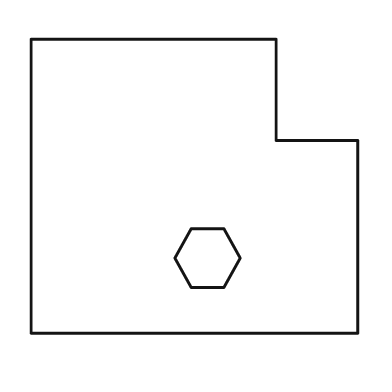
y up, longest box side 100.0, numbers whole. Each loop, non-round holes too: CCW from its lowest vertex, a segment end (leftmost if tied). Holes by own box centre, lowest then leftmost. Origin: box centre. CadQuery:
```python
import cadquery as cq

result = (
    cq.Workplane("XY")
    .moveTo(-50.0, -45.0)
    .lineTo(50.0, -45.0)
    .lineTo(50.0, 14.0)
    .lineTo(25.0, 14.0)
    .lineTo(25.0, 45.0)
    .lineTo(-50.0, 45.0)
    .close()
    .moveTo(-1.0, -31.0)
    .lineTo(9.0, -31.0)
    .lineTo(14.0, -22.0)
    .lineTo(9.0, -13.0)
    .lineTo(-1.0, -13.0)
    .lineTo(-6.0, -22.0)
    .close()
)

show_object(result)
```